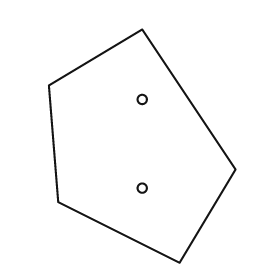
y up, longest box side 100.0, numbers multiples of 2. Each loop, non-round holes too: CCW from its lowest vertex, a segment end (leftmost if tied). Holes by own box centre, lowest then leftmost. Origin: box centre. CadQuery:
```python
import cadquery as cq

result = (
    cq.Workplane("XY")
    .moveTo(16.0, -50.0)
    .lineTo(40.0, -10.0)
    .lineTo(0.0, 50.0)
    .lineTo(-40.0, 26.0)
    .lineTo(-36.0, -24.0)
    .close()
    .moveTo(0.0, -18.0)
    .circle(2.0)
    .moveTo(0.0, 20.0)
    .circle(2.0)
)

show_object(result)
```